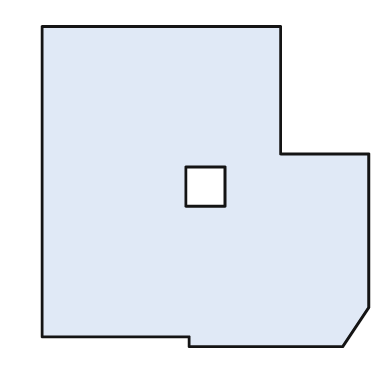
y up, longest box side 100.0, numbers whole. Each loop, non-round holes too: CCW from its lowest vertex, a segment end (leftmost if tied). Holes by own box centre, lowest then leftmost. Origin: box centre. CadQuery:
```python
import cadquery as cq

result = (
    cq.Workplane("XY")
    .moveTo(-5.0, -49.0)
    .lineTo(42.0, -49.0)
    .lineTo(50.0, -37.0)
    .lineTo(50.0, 10.0)
    .lineTo(23.0, 10.0)
    .lineTo(23.0, 49.0)
    .lineTo(-50.0, 49.0)
    .lineTo(-50.0, -46.0)
    .lineTo(-5.0, -46.0)
    .close()
    .moveTo(-6.0, -6.0)
    .lineTo(6.0, -6.0)
    .lineTo(6.0, 6.0)
    .lineTo(-6.0, 6.0)
    .close()
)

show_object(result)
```